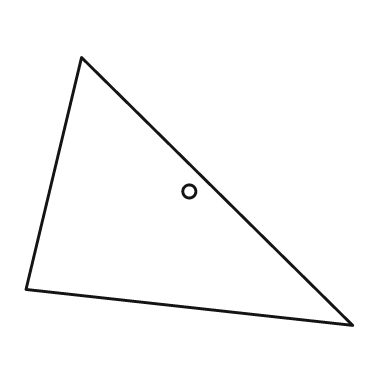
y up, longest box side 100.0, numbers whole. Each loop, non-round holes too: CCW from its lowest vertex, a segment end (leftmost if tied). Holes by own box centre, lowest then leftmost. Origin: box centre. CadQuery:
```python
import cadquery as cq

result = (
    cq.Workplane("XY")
    .moveTo(50.0, -41.0)
    .lineTo(-33.0, 41.0)
    .lineTo(-50.0, -30.0)
    .close()
    .moveTo(0.0, 0.0)
    .circle(2.0)
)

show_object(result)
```